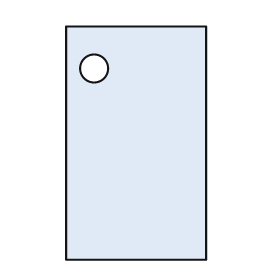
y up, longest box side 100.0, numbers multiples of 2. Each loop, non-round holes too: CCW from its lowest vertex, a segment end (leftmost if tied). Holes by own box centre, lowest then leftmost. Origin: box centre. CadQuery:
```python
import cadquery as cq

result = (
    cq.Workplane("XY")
    .moveTo(-30.0, -50.0)
    .lineTo(30.0, -50.0)
    .lineTo(30.0, 50.0)
    .lineTo(-30.0, 50.0)
    .close()
    .moveTo(-18.0, 32.0)
    .circle(6.0)
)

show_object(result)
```